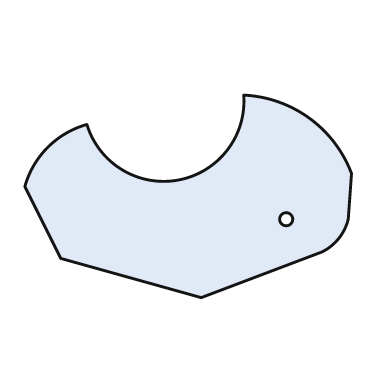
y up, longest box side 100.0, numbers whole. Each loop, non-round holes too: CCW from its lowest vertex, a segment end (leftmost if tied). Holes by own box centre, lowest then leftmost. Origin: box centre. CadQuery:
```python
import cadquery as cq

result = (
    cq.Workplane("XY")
    .moveTo(4.0, -31.0)
    .lineTo(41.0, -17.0)
    .threePointArc((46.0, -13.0), (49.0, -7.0))
    .lineTo(50.0, 7.0)
    .threePointArc((37.0, 24.0), (17.0, 31.0))
    .threePointArc((-3.0, 5.0), (-31.0, 22.0))
    .threePointArc((-43.0, 15.0), (-50.0, 3.0))
    .lineTo(-39.0, -19.0)
    .close()
    .moveTo(30.0, -7.0)
    .circle(2.0)
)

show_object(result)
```